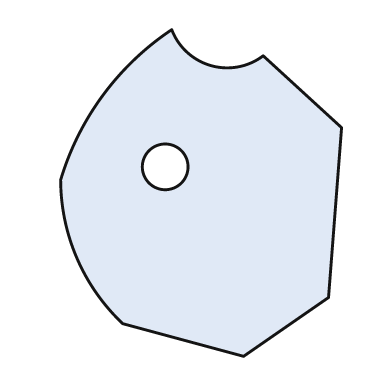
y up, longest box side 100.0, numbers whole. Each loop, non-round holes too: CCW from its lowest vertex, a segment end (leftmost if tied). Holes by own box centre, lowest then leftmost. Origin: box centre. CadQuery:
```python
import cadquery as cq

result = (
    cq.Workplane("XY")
    .moveTo(13.0, -50.0)
    .lineTo(39.0, -32.0)
    .lineTo(43.0, 20.0)
    .lineTo(19.0, 42.0)
    .threePointArc((3.0, 39.0), (-9.0, 50.0))
    .threePointArc((-30.0, 30.0), (-43.0, 4.0))
    .threePointArc((-38.0, -20.0), (-24.0, -40.0))
    .close()
    .moveTo(-11.0, 8.0)
    .circle(7.0)
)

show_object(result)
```